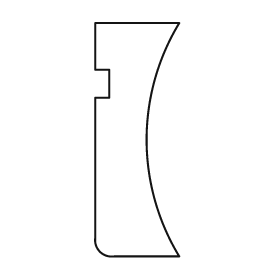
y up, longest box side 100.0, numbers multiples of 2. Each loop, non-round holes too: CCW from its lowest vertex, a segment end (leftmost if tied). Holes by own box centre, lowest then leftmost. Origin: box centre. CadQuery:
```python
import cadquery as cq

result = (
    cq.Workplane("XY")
    .moveTo(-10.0, -50.0)
    .lineTo(18.0, -50.0)
    .threePointArc((4.0, 0.0), (18.0, 50.0))
    .lineTo(-18.0, 50.0)
    .lineTo(-18.0, 30.0)
    .lineTo(-12.0, 30.0)
    .lineTo(-12.0, 18.0)
    .lineTo(-18.0, 18.0)
    .lineTo(-18.0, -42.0)
    .threePointArc((-16.0, -48.0), (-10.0, -50.0))
    .close()
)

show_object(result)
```